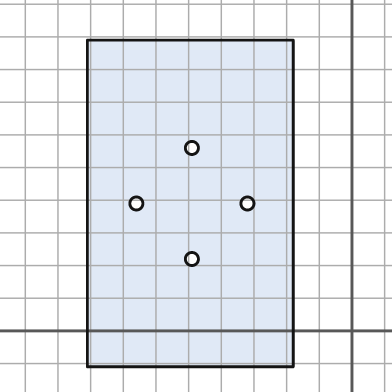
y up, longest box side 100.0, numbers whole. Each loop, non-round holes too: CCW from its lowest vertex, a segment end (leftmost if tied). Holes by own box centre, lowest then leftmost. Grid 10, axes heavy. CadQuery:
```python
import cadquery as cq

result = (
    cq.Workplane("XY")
    .moveTo(-81.0, -11.0)
    .lineTo(-18.0, -11.0)
    .lineTo(-18.0, 89.0)
    .lineTo(-81.0, 89.0)
    .close()
    .moveTo(-49.0, 22.0)
    .circle(2.0)
    .moveTo(-66.0, 39.0)
    .circle(2.0)
    .moveTo(-32.0, 39.0)
    .circle(2.0)
    .moveTo(-49.0, 56.0)
    .circle(2.0)
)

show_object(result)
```